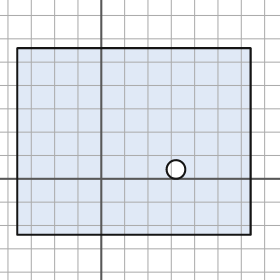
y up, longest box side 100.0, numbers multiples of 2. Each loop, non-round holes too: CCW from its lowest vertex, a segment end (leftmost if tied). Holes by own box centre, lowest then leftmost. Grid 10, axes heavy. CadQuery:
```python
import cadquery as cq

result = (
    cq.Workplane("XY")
    .moveTo(-36.0, -24.0)
    .lineTo(64.0, -24.0)
    .lineTo(64.0, 56.0)
    .lineTo(-36.0, 56.0)
    .close()
    .moveTo(32.0, 4.0)
    .circle(4.0)
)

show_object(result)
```